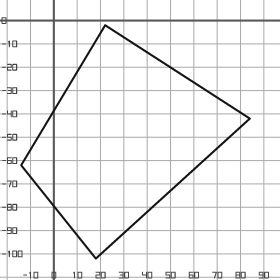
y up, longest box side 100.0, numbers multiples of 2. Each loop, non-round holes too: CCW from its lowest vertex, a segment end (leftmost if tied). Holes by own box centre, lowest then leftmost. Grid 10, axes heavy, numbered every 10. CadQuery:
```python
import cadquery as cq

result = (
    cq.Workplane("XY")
    .moveTo(18.0, -102.0)
    .lineTo(84.0, -42.0)
    .lineTo(22.0, -2.0)
    .lineTo(-14.0, -62.0)
    .close()
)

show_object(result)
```